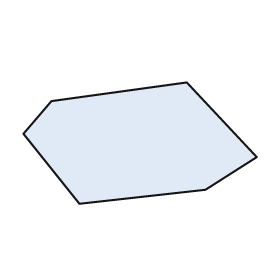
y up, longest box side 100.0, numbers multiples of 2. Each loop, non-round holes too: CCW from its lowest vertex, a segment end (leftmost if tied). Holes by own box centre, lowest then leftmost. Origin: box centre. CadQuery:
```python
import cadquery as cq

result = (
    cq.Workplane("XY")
    .moveTo(-26.0, -26.0)
    .lineTo(28.0, -20.0)
    .lineTo(50.0, -6.0)
    .lineTo(20.0, 26.0)
    .lineTo(-38.0, 18.0)
    .lineTo(-50.0, 4.0)
    .close()
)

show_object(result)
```